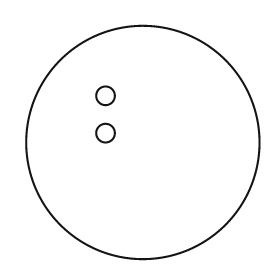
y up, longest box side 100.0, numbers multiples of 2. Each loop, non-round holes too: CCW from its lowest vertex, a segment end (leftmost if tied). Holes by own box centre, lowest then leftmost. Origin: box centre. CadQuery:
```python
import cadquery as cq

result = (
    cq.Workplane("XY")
    .moveTo(0.0, 0.0)
    .circle(50.0)
    .moveTo(-16.0, 4.0)
    .circle(4.0)
    .moveTo(-16.0, 20.0)
    .circle(4.0)
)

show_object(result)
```